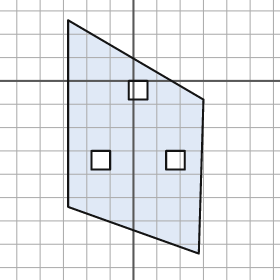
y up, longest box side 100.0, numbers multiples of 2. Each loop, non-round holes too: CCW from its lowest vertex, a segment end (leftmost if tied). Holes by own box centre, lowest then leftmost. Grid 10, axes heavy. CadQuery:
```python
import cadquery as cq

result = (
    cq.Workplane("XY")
    .moveTo(28.0, -74.0)
    .lineTo(30.0, -8.0)
    .lineTo(-28.0, 26.0)
    .lineTo(-28.0, -54.0)
    .close()
    .moveTo(-18.0, -38.0)
    .lineTo(-10.0, -38.0)
    .lineTo(-10.0, -30.0)
    .lineTo(-18.0, -30.0)
    .close()
    .moveTo(14.0, -38.0)
    .lineTo(22.0, -38.0)
    .lineTo(22.0, -30.0)
    .lineTo(14.0, -30.0)
    .close()
    .moveTo(-2.0, -8.0)
    .lineTo(6.0, -8.0)
    .lineTo(6.0, 0.0)
    .lineTo(-2.0, 0.0)
    .close()
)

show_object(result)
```